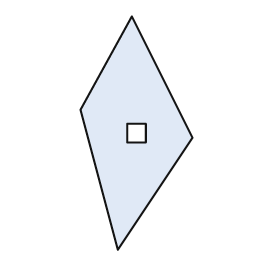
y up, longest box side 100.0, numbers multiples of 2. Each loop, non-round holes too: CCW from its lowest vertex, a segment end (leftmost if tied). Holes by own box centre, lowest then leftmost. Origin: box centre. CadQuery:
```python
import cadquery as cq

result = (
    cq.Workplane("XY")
    .moveTo(-8.0, -50.0)
    .lineTo(24.0, -2.0)
    .lineTo(-2.0, 50.0)
    .lineTo(-24.0, 10.0)
    .close()
    .moveTo(-4.0, -4.0)
    .lineTo(4.0, -4.0)
    .lineTo(4.0, 4.0)
    .lineTo(-4.0, 4.0)
    .close()
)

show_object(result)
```